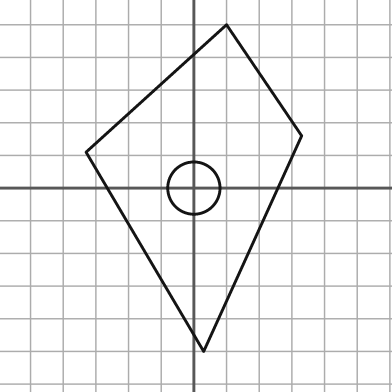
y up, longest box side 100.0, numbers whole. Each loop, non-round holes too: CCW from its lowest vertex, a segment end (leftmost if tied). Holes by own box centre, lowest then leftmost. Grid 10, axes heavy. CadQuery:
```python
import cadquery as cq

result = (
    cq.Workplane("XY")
    .moveTo(3.0, -50.0)
    .lineTo(33.0, 16.0)
    .lineTo(10.0, 50.0)
    .lineTo(-33.0, 11.0)
    .close()
    .moveTo(0.0, 0.0)
    .circle(8.0)
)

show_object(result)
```